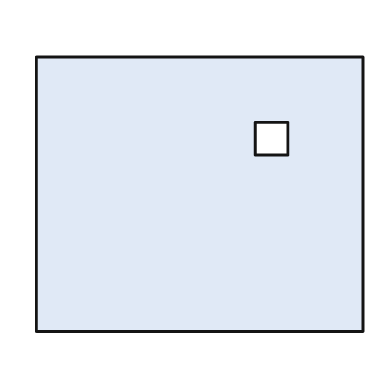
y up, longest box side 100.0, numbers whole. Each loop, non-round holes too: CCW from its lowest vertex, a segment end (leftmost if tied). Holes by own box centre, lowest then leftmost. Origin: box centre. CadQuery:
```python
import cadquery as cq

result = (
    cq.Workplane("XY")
    .moveTo(-50.0, -42.0)
    .lineTo(50.0, -42.0)
    .lineTo(50.0, 42.0)
    .lineTo(-50.0, 42.0)
    .close()
    .moveTo(17.0, 12.0)
    .lineTo(27.0, 12.0)
    .lineTo(27.0, 22.0)
    .lineTo(17.0, 22.0)
    .close()
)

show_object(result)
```